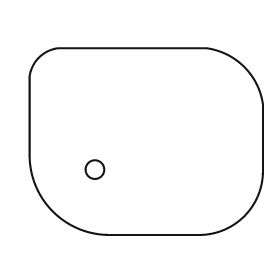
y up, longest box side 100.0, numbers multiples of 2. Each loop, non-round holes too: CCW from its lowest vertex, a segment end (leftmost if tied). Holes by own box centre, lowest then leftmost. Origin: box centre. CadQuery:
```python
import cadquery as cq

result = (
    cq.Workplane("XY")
    .moveTo(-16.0, -40.0)
    .lineTo(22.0, -40.0)
    .threePointArc((42.0, -32.0), (50.0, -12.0))
    .lineTo(50.0, 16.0)
    .threePointArc((42.0, 32.0), (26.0, 40.0))
    .lineTo(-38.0, 40.0)
    .threePointArc((-46.0, 36.0), (-50.0, 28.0))
    .lineTo(-50.0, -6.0)
    .threePointArc((-40.0, -30.0), (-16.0, -40.0))
    .close()
    .moveTo(-22.0, -12.0)
    .circle(4.0)
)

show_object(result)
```